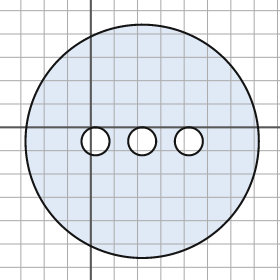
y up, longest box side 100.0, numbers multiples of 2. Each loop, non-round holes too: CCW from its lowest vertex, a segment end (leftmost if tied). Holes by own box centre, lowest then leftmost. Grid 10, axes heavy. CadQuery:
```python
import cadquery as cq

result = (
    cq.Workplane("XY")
    .moveTo(22.0, -6.0)
    .circle(50.0)
    .moveTo(2.0, -6.0)
    .circle(6.0)
    .moveTo(22.0, -6.0)
    .circle(6.0)
    .moveTo(42.0, -6.0)
    .circle(6.0)
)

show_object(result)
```